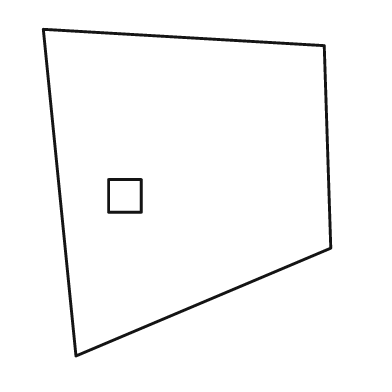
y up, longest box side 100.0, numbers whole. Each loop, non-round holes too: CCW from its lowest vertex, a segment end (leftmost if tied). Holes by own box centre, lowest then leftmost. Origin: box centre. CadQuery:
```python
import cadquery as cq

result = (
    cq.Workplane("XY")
    .moveTo(-34.0, -50.0)
    .lineTo(44.0, -17.0)
    .lineTo(42.0, 45.0)
    .lineTo(-44.0, 50.0)
    .close()
    .moveTo(-24.0, -6.0)
    .lineTo(-14.0, -6.0)
    .lineTo(-14.0, 4.0)
    .lineTo(-24.0, 4.0)
    .close()
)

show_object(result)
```